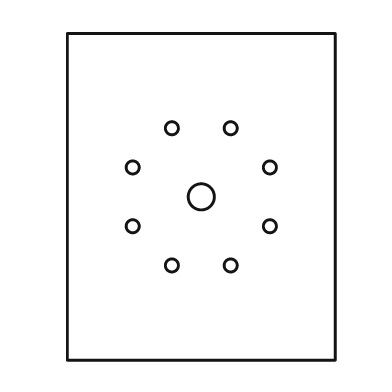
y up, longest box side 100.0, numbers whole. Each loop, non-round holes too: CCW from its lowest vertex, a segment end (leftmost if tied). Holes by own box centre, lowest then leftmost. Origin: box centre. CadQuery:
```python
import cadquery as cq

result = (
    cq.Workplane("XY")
    .moveTo(-41.0, -50.0)
    .lineTo(41.0, -50.0)
    .lineTo(41.0, 50.0)
    .lineTo(-41.0, 50.0)
    .close()
    .moveTo(-9.0, -21.0)
    .circle(2.0)
    .moveTo(9.0, -21.0)
    .circle(2.0)
    .moveTo(-21.0, -9.0)
    .circle(2.0)
    .moveTo(21.0, -9.0)
    .circle(2.0)
    .moveTo(0.0, 0.0)
    .circle(4.0)
    .moveTo(-21.0, 9.0)
    .circle(2.0)
    .moveTo(21.0, 9.0)
    .circle(2.0)
    .moveTo(-9.0, 21.0)
    .circle(2.0)
    .moveTo(9.0, 21.0)
    .circle(2.0)
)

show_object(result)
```